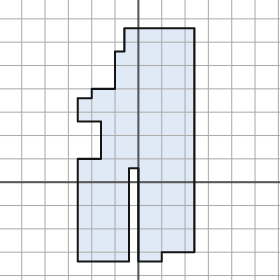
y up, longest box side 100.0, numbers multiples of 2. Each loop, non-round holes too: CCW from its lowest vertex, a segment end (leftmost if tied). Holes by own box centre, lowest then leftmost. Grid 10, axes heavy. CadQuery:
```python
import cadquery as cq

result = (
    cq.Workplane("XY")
    .moveTo(-26.0, -34.0)
    .lineTo(-4.0, -34.0)
    .lineTo(-4.0, 6.0)
    .lineTo(0.0, 6.0)
    .lineTo(0.0, -34.0)
    .lineTo(10.0, -34.0)
    .lineTo(10.0, -30.0)
    .lineTo(24.0, -30.0)
    .lineTo(24.0, 66.0)
    .lineTo(-6.0, 66.0)
    .lineTo(-6.0, 56.0)
    .lineTo(-10.0, 56.0)
    .lineTo(-10.0, 40.0)
    .lineTo(-20.0, 40.0)
    .lineTo(-20.0, 36.0)
    .lineTo(-26.0, 36.0)
    .lineTo(-26.0, 26.0)
    .lineTo(-16.0, 26.0)
    .lineTo(-16.0, 10.0)
    .lineTo(-26.0, 10.0)
    .close()
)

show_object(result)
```